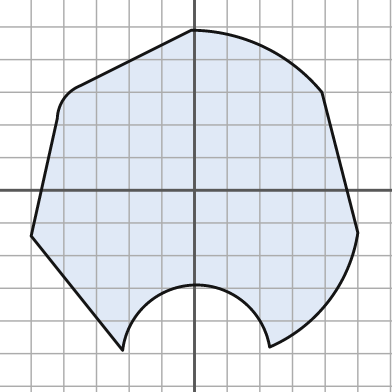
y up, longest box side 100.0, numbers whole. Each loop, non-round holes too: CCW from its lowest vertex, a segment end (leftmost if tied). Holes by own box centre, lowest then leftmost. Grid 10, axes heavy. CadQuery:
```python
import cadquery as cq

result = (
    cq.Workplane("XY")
    .moveTo(-22.0, -49.0)
    .threePointArc((0.0, -29.0), (23.0, -48.0))
    .threePointArc((41.0, -34.0), (50.0, -13.0))
    .lineTo(39.0, 30.0)
    .threePointArc((21.0, 44.0), (-1.0, 49.0))
    .lineTo(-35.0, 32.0)
    .threePointArc((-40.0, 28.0), (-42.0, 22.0))
    .lineTo(-50.0, -14.0)
    .close()
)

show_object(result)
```